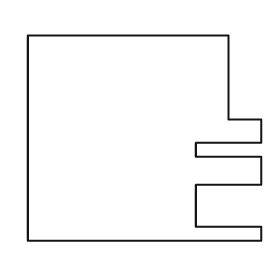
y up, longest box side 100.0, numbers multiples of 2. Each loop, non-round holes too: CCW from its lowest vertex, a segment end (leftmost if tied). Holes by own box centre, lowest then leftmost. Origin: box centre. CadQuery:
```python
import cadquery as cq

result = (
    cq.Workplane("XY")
    .moveTo(-50.0, -44.0)
    .lineTo(50.0, -44.0)
    .lineTo(50.0, -38.0)
    .lineTo(22.0, -38.0)
    .lineTo(22.0, -20.0)
    .lineTo(50.0, -20.0)
    .lineTo(50.0, -8.0)
    .lineTo(22.0, -8.0)
    .lineTo(22.0, -2.0)
    .lineTo(50.0, -2.0)
    .lineTo(50.0, 8.0)
    .lineTo(36.0, 8.0)
    .lineTo(36.0, 44.0)
    .lineTo(-50.0, 44.0)
    .close()
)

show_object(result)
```